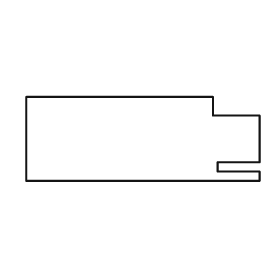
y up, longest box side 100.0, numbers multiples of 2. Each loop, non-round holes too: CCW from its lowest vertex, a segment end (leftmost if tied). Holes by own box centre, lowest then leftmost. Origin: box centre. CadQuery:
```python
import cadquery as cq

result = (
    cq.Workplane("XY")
    .moveTo(-50.0, -18.0)
    .lineTo(50.0, -18.0)
    .lineTo(50.0, -14.0)
    .lineTo(32.0, -14.0)
    .lineTo(32.0, -10.0)
    .lineTo(50.0, -10.0)
    .lineTo(50.0, 10.0)
    .lineTo(30.0, 10.0)
    .lineTo(30.0, 18.0)
    .lineTo(-50.0, 18.0)
    .close()
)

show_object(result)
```